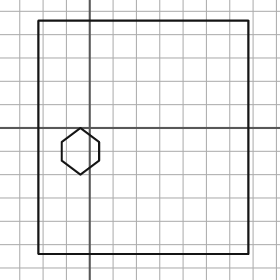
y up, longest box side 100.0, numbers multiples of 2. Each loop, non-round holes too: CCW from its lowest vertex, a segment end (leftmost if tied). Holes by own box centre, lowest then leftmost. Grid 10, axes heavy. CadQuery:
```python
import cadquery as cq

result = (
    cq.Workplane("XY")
    .moveTo(-22.0, -54.0)
    .lineTo(68.0, -54.0)
    .lineTo(68.0, 46.0)
    .lineTo(-22.0, 46.0)
    .close()
    .moveTo(-4.0, -20.0)
    .lineTo(4.0, -14.0)
    .lineTo(4.0, -6.0)
    .lineTo(-4.0, 0.0)
    .lineTo(-12.0, -6.0)
    .lineTo(-12.0, -14.0)
    .close()
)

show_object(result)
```